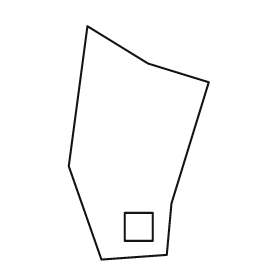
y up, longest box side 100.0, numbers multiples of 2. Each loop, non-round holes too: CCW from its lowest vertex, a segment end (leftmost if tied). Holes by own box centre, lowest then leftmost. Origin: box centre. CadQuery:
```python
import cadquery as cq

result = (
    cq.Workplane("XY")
    .moveTo(-16.0, -50.0)
    .lineTo(12.0, -48.0)
    .lineTo(14.0, -26.0)
    .lineTo(30.0, 26.0)
    .lineTo(4.0, 34.0)
    .lineTo(-22.0, 50.0)
    .lineTo(-30.0, -10.0)
    .close()
    .moveTo(-6.0, -42.0)
    .lineTo(6.0, -42.0)
    .lineTo(6.0, -30.0)
    .lineTo(-6.0, -30.0)
    .close()
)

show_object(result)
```